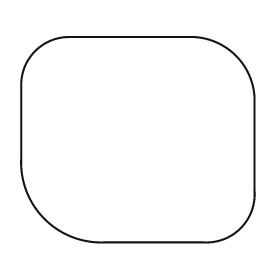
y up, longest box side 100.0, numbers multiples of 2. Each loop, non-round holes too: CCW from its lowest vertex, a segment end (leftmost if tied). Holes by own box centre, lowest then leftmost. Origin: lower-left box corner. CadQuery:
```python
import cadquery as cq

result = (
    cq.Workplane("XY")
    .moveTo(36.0, 0.0)
    .lineTo(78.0, 0.0)
    .threePointArc((94.0, 6.0), (100.0, 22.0))
    .lineTo(100.0, 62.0)
    .threePointArc((92.0, 80.0), (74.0, 88.0))
    .lineTo(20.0, 88.0)
    .threePointArc((6.0, 82.0), (0.0, 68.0))
    .lineTo(0.0, 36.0)
    .threePointArc((10.0, 10.0), (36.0, 0.0))
    .close()
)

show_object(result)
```